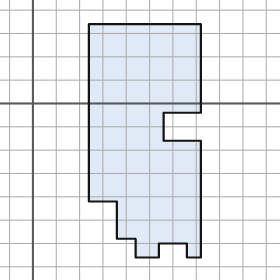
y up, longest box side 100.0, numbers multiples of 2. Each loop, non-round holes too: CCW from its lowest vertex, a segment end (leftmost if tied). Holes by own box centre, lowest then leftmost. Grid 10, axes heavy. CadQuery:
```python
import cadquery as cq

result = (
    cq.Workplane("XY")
    .moveTo(44.0, -66.0)
    .lineTo(54.0, -66.0)
    .lineTo(54.0, -60.0)
    .lineTo(66.0, -60.0)
    .lineTo(66.0, -66.0)
    .lineTo(72.0, -66.0)
    .lineTo(72.0, -16.0)
    .lineTo(56.0, -16.0)
    .lineTo(56.0, -4.0)
    .lineTo(72.0, -4.0)
    .lineTo(72.0, 34.0)
    .lineTo(24.0, 34.0)
    .lineTo(24.0, -42.0)
    .lineTo(36.0, -42.0)
    .lineTo(36.0, -58.0)
    .lineTo(44.0, -58.0)
    .close()
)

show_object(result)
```